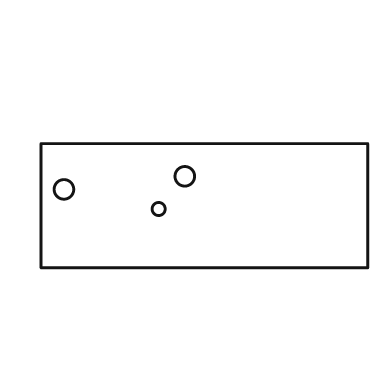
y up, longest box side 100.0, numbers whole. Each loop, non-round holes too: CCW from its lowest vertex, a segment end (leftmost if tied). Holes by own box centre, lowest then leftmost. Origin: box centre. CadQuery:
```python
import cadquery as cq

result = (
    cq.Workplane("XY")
    .moveTo(-50.0, -19.0)
    .lineTo(50.0, -19.0)
    .lineTo(50.0, 19.0)
    .lineTo(-50.0, 19.0)
    .close()
    .moveTo(-14.0, -1.0)
    .circle(2.0)
    .moveTo(-43.0, 5.0)
    .circle(3.0)
    .moveTo(-6.0, 9.0)
    .circle(3.0)
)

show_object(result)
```